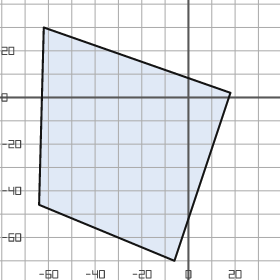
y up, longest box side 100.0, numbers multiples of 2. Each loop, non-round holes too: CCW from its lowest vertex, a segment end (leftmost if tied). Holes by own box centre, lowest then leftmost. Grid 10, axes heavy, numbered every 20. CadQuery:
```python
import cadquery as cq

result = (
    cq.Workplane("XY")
    .moveTo(-6.0, -70.0)
    .lineTo(18.0, 2.0)
    .lineTo(-62.0, 30.0)
    .lineTo(-64.0, -46.0)
    .close()
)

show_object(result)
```